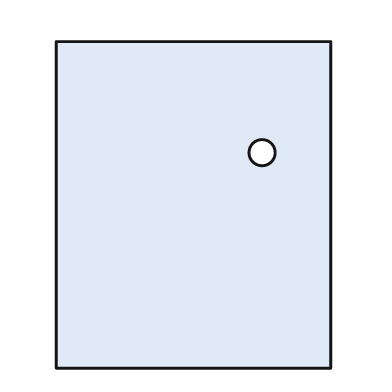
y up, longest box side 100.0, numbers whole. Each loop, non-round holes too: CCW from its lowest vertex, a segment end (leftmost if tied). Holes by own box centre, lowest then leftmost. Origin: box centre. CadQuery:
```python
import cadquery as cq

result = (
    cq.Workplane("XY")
    .moveTo(-42.0, -50.0)
    .lineTo(42.0, -50.0)
    .lineTo(42.0, 50.0)
    .lineTo(-42.0, 50.0)
    .close()
    .moveTo(21.0, 16.0)
    .circle(4.0)
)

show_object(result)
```